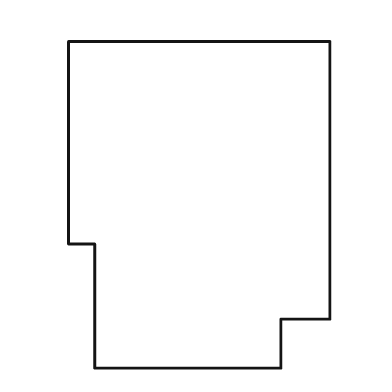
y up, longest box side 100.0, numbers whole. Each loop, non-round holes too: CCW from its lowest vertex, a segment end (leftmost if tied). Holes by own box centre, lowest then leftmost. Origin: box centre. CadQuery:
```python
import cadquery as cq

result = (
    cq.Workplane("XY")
    .moveTo(-32.0, -50.0)
    .lineTo(25.0, -50.0)
    .lineTo(25.0, -35.0)
    .lineTo(40.0, -35.0)
    .lineTo(40.0, 50.0)
    .lineTo(-40.0, 50.0)
    .lineTo(-40.0, -12.0)
    .lineTo(-32.0, -12.0)
    .close()
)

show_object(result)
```